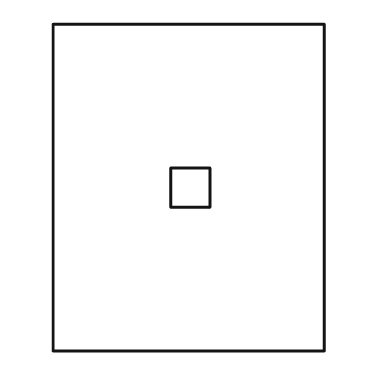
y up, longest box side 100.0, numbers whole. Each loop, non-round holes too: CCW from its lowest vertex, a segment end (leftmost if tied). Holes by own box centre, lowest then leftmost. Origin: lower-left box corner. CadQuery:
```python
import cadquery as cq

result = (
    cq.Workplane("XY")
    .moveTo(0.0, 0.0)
    .lineTo(83.0, 0.0)
    .lineTo(83.0, 100.0)
    .lineTo(0.0, 100.0)
    .close()
    .moveTo(36.0, 44.0)
    .lineTo(48.0, 44.0)
    .lineTo(48.0, 56.0)
    .lineTo(36.0, 56.0)
    .close()
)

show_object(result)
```